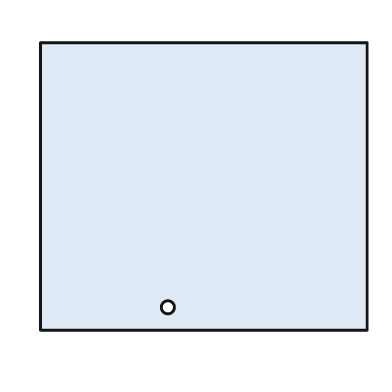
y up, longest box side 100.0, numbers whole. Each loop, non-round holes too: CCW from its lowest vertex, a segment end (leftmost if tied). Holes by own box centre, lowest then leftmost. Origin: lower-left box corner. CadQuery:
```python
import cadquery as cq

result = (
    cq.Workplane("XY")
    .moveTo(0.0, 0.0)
    .lineTo(100.0, 0.0)
    .lineTo(100.0, 88.0)
    .lineTo(0.0, 88.0)
    .close()
    .moveTo(39.0, 7.0)
    .circle(2.0)
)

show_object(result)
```